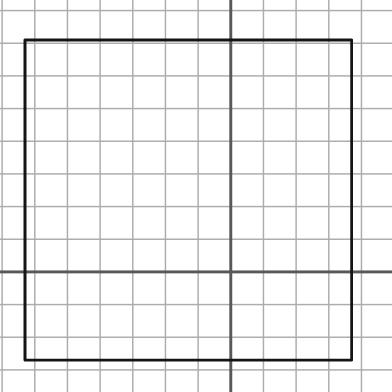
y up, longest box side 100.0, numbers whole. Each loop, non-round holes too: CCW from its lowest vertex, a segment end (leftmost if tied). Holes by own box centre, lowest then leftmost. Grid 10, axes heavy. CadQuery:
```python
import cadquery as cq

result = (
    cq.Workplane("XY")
    .moveTo(-63.0, -27.0)
    .lineTo(37.0, -27.0)
    .lineTo(37.0, 71.0)
    .lineTo(-63.0, 71.0)
    .close()
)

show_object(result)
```